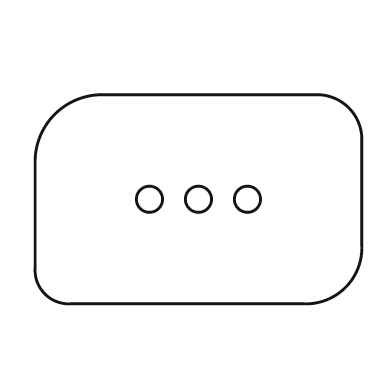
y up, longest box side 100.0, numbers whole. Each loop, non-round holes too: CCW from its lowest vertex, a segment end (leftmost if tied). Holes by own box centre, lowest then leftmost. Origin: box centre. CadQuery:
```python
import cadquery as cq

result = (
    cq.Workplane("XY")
    .moveTo(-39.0, -32.0)
    .lineTo(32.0, -32.0)
    .threePointArc((45.0, -27.0), (50.0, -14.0))
    .lineTo(50.0, 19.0)
    .threePointArc((46.0, 28.0), (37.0, 32.0))
    .lineTo(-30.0, 32.0)
    .threePointArc((-44.0, 26.0), (-50.0, 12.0))
    .lineTo(-50.0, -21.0)
    .threePointArc((-47.0, -29.0), (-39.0, -32.0))
    .close()
    .moveTo(-15.0, 0.0)
    .circle(4.0)
    .moveTo(0.0, 0.0)
    .circle(4.0)
    .moveTo(15.0, 0.0)
    .circle(4.0)
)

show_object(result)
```